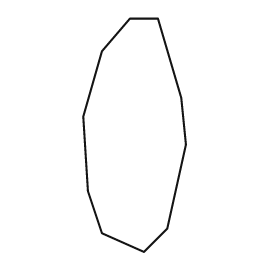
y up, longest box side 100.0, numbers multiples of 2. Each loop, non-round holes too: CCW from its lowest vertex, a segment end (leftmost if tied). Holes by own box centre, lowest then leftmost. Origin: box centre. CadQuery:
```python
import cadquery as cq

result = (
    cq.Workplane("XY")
    .moveTo(4.0, -50.0)
    .lineTo(14.0, -40.0)
    .lineTo(22.0, -4.0)
    .lineTo(20.0, 16.0)
    .lineTo(10.0, 50.0)
    .lineTo(-2.0, 50.0)
    .lineTo(-14.0, 36.0)
    .lineTo(-22.0, 8.0)
    .lineTo(-20.0, -24.0)
    .lineTo(-14.0, -42.0)
    .close()
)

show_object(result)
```